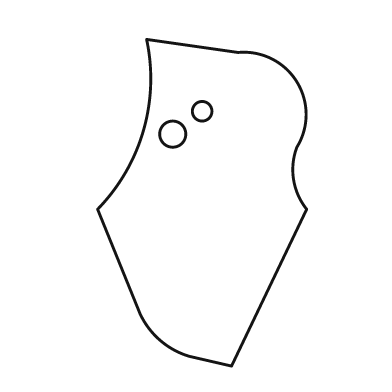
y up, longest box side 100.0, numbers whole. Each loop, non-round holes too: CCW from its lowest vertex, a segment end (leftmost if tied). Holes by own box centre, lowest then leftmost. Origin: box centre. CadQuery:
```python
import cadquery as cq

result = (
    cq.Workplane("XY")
    .moveTo(9.0, -50.0)
    .lineTo(32.0, -2.0)
    .threePointArc((28.0, 7.0), (29.0, 17.0))
    .threePointArc((29.0, 37.0), (11.0, 46.0))
    .lineTo(-17.0, 50.0)
    .threePointArc((-18.0, 22.0), (-32.0, -2.0))
    .lineTo(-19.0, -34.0)
    .threePointArc((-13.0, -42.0), (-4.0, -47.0))
    .close()
    .moveTo(-9.0, 21.0)
    .circle(4.0)
    .moveTo(0.0, 28.0)
    .circle(3.0)
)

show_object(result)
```